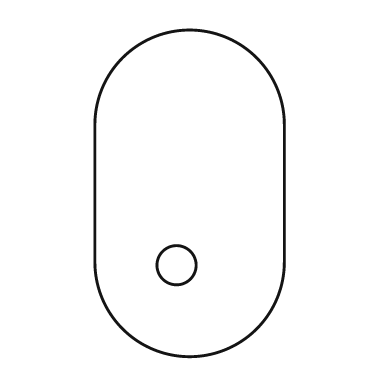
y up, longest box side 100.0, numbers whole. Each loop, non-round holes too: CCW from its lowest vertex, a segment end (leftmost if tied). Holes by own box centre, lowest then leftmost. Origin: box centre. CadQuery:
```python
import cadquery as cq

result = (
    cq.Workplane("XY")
    .moveTo(-29.0, -21.0)
    .threePointArc((0.0, -50.0), (29.0, -21.0))
    .lineTo(29.0, 21.0)
    .threePointArc((0.0, 50.0), (-29.0, 21.0))
    .close()
    .moveTo(-4.0, -22.0)
    .circle(6.0)
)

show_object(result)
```